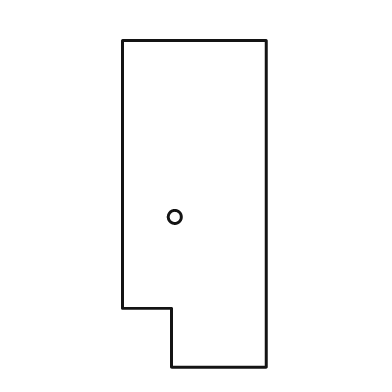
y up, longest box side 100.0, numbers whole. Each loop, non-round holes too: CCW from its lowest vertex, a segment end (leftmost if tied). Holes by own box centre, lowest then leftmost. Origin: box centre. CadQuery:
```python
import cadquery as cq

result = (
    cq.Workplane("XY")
    .moveTo(-7.0, -50.0)
    .lineTo(22.0, -50.0)
    .lineTo(22.0, 50.0)
    .lineTo(-22.0, 50.0)
    .lineTo(-22.0, -32.0)
    .lineTo(-7.0, -32.0)
    .close()
    .moveTo(-6.0, -4.0)
    .circle(2.0)
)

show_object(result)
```